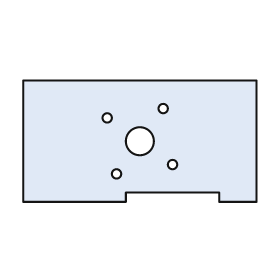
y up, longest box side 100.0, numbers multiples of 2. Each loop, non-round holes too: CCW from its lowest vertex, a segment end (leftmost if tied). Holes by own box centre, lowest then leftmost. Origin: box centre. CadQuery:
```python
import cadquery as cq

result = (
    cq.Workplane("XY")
    .moveTo(-50.0, -26.0)
    .lineTo(-6.0, -26.0)
    .lineTo(-6.0, -22.0)
    .lineTo(34.0, -22.0)
    .lineTo(34.0, -26.0)
    .lineTo(50.0, -26.0)
    .lineTo(50.0, 26.0)
    .lineTo(-50.0, 26.0)
    .close()
    .moveTo(-10.0, -14.0)
    .circle(2.0)
    .moveTo(14.0, -10.0)
    .circle(2.0)
    .moveTo(0.0, 0.0)
    .circle(6.0)
    .moveTo(-14.0, 10.0)
    .circle(2.0)
    .moveTo(10.0, 14.0)
    .circle(2.0)
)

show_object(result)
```